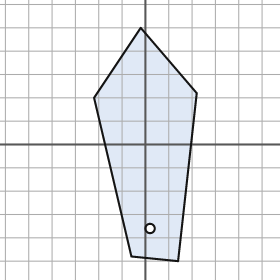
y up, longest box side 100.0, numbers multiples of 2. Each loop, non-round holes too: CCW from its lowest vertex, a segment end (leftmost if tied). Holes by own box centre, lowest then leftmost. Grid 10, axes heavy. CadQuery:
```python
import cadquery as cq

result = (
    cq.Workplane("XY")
    .moveTo(14.0, -50.0)
    .lineTo(22.0, 22.0)
    .lineTo(-2.0, 50.0)
    .lineTo(-22.0, 20.0)
    .lineTo(-6.0, -48.0)
    .close()
    .moveTo(2.0, -36.0)
    .circle(2.0)
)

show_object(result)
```